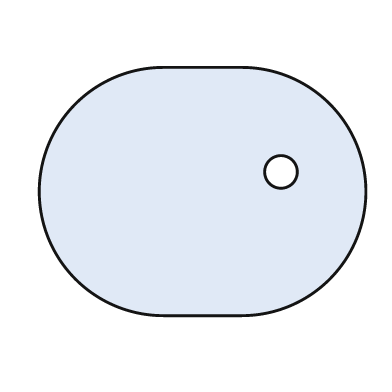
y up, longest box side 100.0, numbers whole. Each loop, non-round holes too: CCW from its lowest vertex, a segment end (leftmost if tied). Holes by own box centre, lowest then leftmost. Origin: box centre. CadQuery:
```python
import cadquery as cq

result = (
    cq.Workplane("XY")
    .moveTo(-12.0, -38.0)
    .lineTo(12.0, -38.0)
    .threePointArc((50.0, 0.0), (12.0, 38.0))
    .lineTo(-12.0, 38.0)
    .threePointArc((-50.0, 0.0), (-12.0, -38.0))
    .close()
    .moveTo(24.0, 6.0)
    .circle(5.0)
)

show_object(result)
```